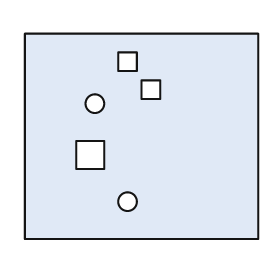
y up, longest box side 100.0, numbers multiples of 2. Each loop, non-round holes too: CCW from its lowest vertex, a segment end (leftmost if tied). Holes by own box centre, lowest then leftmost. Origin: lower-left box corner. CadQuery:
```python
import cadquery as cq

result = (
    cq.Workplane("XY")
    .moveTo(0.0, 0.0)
    .lineTo(100.0, 0.0)
    .lineTo(100.0, 88.0)
    .lineTo(0.0, 88.0)
    .close()
    .moveTo(44.0, 16.0)
    .circle(4.0)
    .moveTo(22.0, 30.0)
    .lineTo(34.0, 30.0)
    .lineTo(34.0, 42.0)
    .lineTo(22.0, 42.0)
    .close()
    .moveTo(30.0, 58.0)
    .circle(4.0)
    .moveTo(50.0, 60.0)
    .lineTo(58.0, 60.0)
    .lineTo(58.0, 68.0)
    .lineTo(50.0, 68.0)
    .close()
    .moveTo(40.0, 72.0)
    .lineTo(48.0, 72.0)
    .lineTo(48.0, 80.0)
    .lineTo(40.0, 80.0)
    .close()
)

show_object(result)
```